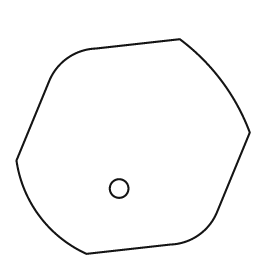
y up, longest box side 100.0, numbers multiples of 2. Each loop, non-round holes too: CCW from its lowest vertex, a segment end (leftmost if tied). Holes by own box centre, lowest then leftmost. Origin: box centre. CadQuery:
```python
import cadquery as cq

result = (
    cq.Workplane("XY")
    .moveTo(-20.0, -46.0)
    .lineTo(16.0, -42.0)
    .threePointArc((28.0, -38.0), (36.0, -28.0))
    .lineTo(50.0, 6.0)
    .threePointArc((38.0, 28.0), (20.0, 46.0))
    .lineTo(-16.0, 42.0)
    .threePointArc((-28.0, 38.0), (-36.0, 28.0))
    .lineTo(-50.0, -6.0)
    .threePointArc((-40.0, -30.0), (-20.0, -46.0))
    .close()
    .moveTo(-6.0, -18.0)
    .circle(4.0)
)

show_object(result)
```